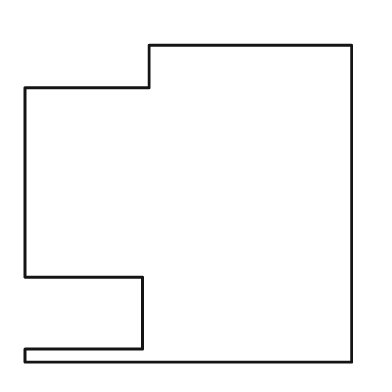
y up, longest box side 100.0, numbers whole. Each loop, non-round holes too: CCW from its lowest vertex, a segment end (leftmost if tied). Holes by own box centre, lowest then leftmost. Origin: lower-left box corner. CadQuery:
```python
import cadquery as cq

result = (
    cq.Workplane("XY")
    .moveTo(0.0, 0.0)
    .lineTo(100.0, 0.0)
    .lineTo(100.0, 97.0)
    .lineTo(38.0, 97.0)
    .lineTo(38.0, 84.0)
    .lineTo(0.0, 84.0)
    .lineTo(0.0, 26.0)
    .lineTo(36.0, 26.0)
    .lineTo(36.0, 4.0)
    .lineTo(0.0, 4.0)
    .close()
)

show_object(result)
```